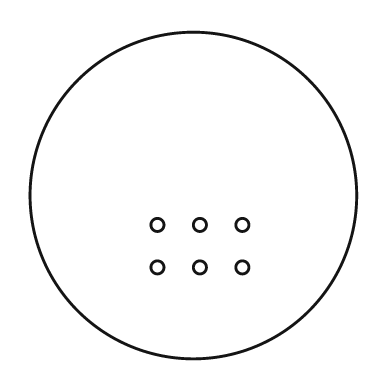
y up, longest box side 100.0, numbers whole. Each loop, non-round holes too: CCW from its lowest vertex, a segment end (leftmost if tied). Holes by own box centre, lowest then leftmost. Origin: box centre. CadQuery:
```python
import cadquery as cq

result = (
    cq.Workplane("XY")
    .moveTo(0.0, 0.0)
    .circle(50.0)
    .moveTo(-11.0, -22.0)
    .circle(2.0)
    .moveTo(2.0, -22.0)
    .circle(2.0)
    .moveTo(15.0, -22.0)
    .circle(2.0)
    .moveTo(-11.0, -9.0)
    .circle(2.0)
    .moveTo(2.0, -9.0)
    .circle(2.0)
    .moveTo(15.0, -9.0)
    .circle(2.0)
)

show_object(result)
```